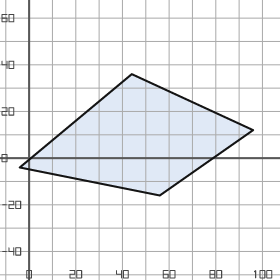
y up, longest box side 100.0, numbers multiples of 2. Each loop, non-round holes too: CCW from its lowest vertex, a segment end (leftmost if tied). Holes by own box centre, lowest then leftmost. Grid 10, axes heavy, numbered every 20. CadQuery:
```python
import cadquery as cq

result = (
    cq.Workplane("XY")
    .moveTo(56.0, -16.0)
    .lineTo(96.0, 12.0)
    .lineTo(44.0, 36.0)
    .lineTo(-4.0, -4.0)
    .close()
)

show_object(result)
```